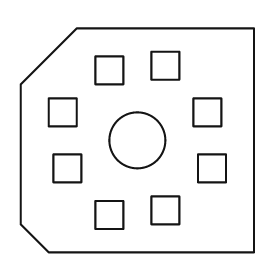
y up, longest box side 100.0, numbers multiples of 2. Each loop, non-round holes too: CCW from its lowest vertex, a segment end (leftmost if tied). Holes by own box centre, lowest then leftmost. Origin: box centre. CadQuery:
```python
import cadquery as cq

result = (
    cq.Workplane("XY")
    .moveTo(-38.0, -48.0)
    .lineTo(50.0, -48.0)
    .lineTo(50.0, 48.0)
    .lineTo(-26.0, 48.0)
    .lineTo(-50.0, 24.0)
    .lineTo(-50.0, -36.0)
    .close()
    .moveTo(-18.0, -38.0)
    .lineTo(-6.0, -38.0)
    .lineTo(-6.0, -26.0)
    .lineTo(-18.0, -26.0)
    .close()
    .moveTo(6.0, -36.0)
    .lineTo(18.0, -36.0)
    .lineTo(18.0, -24.0)
    .lineTo(6.0, -24.0)
    .close()
    .moveTo(-36.0, -18.0)
    .lineTo(-24.0, -18.0)
    .lineTo(-24.0, -6.0)
    .lineTo(-36.0, -6.0)
    .close()
    .moveTo(26.0, -18.0)
    .lineTo(38.0, -18.0)
    .lineTo(38.0, -6.0)
    .lineTo(26.0, -6.0)
    .close()
    .moveTo(0.0, 0.0)
    .circle(12.0)
    .moveTo(-38.0, 6.0)
    .lineTo(-26.0, 6.0)
    .lineTo(-26.0, 18.0)
    .lineTo(-38.0, 18.0)
    .close()
    .moveTo(24.0, 6.0)
    .lineTo(36.0, 6.0)
    .lineTo(36.0, 18.0)
    .lineTo(24.0, 18.0)
    .close()
    .moveTo(-18.0, 24.0)
    .lineTo(-6.0, 24.0)
    .lineTo(-6.0, 36.0)
    .lineTo(-18.0, 36.0)
    .close()
    .moveTo(6.0, 26.0)
    .lineTo(18.0, 26.0)
    .lineTo(18.0, 38.0)
    .lineTo(6.0, 38.0)
    .close()
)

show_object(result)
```